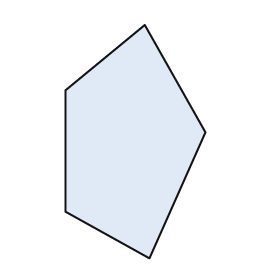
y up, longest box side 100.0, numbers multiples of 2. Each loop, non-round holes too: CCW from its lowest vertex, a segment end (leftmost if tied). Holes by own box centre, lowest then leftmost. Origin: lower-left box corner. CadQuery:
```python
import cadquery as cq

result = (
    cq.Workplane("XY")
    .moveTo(36.0, 0.0)
    .lineTo(60.0, 54.0)
    .lineTo(34.0, 100.0)
    .lineTo(0.0, 72.0)
    .lineTo(0.0, 20.0)
    .close()
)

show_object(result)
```